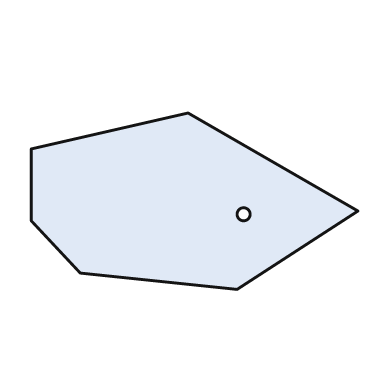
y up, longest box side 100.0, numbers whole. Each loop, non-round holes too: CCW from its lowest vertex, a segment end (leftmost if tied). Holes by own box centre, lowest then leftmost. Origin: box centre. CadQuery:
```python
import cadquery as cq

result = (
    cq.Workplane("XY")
    .moveTo(13.0, -27.0)
    .lineTo(50.0, -3.0)
    .lineTo(-2.0, 27.0)
    .lineTo(-50.0, 16.0)
    .lineTo(-50.0, -6.0)
    .lineTo(-35.0, -22.0)
    .close()
    .moveTo(15.0, -4.0)
    .circle(2.0)
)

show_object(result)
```